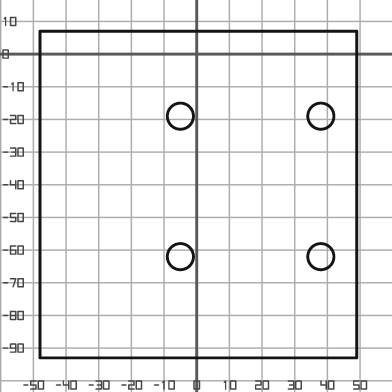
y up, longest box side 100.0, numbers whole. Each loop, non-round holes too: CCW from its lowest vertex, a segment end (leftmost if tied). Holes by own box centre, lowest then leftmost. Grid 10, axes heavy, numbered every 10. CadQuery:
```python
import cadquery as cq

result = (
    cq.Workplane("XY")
    .moveTo(-48.0, -93.0)
    .lineTo(49.0, -93.0)
    .lineTo(49.0, 7.0)
    .lineTo(-48.0, 7.0)
    .close()
    .moveTo(-5.0, -62.0)
    .circle(4.0)
    .moveTo(38.0, -62.0)
    .circle(4.0)
    .moveTo(-5.0, -19.0)
    .circle(4.0)
    .moveTo(38.0, -19.0)
    .circle(4.0)
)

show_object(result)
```